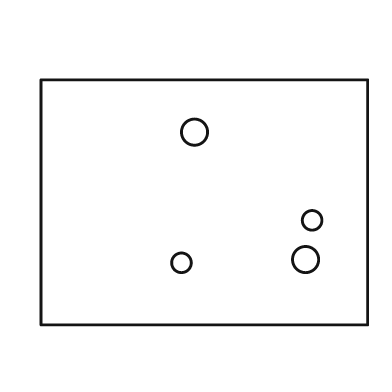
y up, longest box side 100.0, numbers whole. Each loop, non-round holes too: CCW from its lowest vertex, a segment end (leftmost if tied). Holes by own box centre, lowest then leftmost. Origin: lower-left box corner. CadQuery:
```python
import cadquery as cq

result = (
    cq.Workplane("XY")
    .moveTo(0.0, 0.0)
    .lineTo(100.0, 0.0)
    .lineTo(100.0, 75.0)
    .lineTo(0.0, 75.0)
    .close()
    .moveTo(43.0, 19.0)
    .circle(3.0)
    .moveTo(81.0, 20.0)
    .circle(4.0)
    .moveTo(83.0, 32.0)
    .circle(3.0)
    .moveTo(47.0, 59.0)
    .circle(4.0)
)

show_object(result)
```